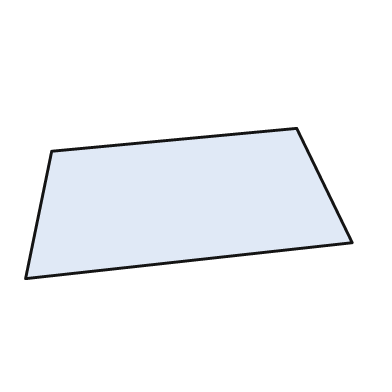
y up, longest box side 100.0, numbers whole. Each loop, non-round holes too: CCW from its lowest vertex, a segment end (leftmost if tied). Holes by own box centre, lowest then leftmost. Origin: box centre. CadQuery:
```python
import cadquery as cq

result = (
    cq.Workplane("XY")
    .moveTo(-50.0, -23.0)
    .lineTo(50.0, -12.0)
    .lineTo(33.0, 23.0)
    .lineTo(-42.0, 16.0)
    .close()
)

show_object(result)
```